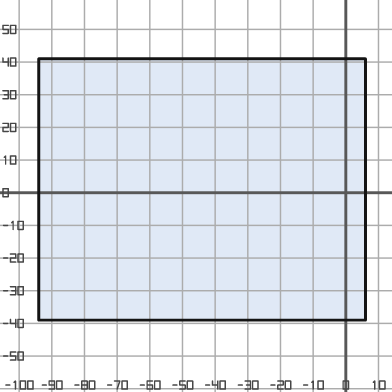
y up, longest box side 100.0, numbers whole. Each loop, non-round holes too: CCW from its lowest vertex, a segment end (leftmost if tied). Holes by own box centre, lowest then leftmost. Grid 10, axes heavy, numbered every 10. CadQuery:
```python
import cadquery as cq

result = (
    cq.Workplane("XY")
    .moveTo(-94.0, -39.0)
    .lineTo(6.0, -39.0)
    .lineTo(6.0, 41.0)
    .lineTo(-94.0, 41.0)
    .close()
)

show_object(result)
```